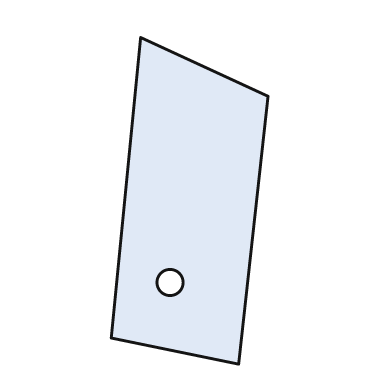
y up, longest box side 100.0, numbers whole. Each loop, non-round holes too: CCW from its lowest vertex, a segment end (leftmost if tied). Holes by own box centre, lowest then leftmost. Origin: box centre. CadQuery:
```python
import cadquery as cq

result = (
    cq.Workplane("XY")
    .moveTo(15.0, -50.0)
    .lineTo(24.0, 32.0)
    .lineTo(-15.0, 50.0)
    .lineTo(-24.0, -42.0)
    .close()
    .moveTo(-6.0, -25.0)
    .circle(4.0)
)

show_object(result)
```